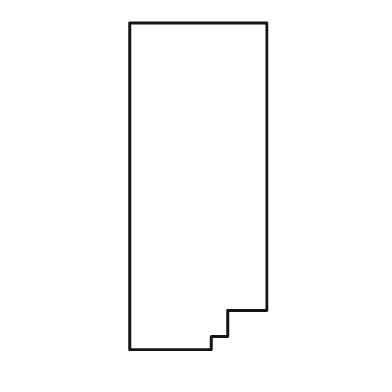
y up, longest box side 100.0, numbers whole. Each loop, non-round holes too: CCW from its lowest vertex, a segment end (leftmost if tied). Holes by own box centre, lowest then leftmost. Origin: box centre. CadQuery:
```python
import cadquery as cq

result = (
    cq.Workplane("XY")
    .moveTo(-21.0, -50.0)
    .lineTo(4.0, -50.0)
    .lineTo(4.0, -46.0)
    .lineTo(9.0, -46.0)
    .lineTo(9.0, -38.0)
    .lineTo(21.0, -38.0)
    .lineTo(21.0, 50.0)
    .lineTo(-21.0, 50.0)
    .close()
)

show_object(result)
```